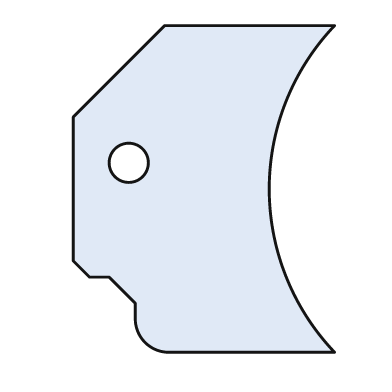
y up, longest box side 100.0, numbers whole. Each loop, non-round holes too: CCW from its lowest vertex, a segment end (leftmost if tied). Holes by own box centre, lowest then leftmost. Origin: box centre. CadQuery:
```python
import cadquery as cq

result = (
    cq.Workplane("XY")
    .moveTo(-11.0, -50.0)
    .lineTo(40.0, -50.0)
    .threePointArc((20.0, 0.0), (40.0, 50.0))
    .lineTo(-12.0, 50.0)
    .lineTo(-40.0, 22.0)
    .lineTo(-40.0, -22.0)
    .lineTo(-35.0, -27.0)
    .lineTo(-29.0, -27.0)
    .lineTo(-21.0, -35.0)
    .lineTo(-21.0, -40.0)
    .threePointArc((-18.0, -47.0), (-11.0, -50.0))
    .close()
    .moveTo(-23.0, 8.0)
    .circle(6.0)
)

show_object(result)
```